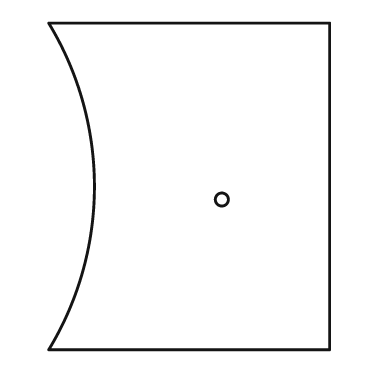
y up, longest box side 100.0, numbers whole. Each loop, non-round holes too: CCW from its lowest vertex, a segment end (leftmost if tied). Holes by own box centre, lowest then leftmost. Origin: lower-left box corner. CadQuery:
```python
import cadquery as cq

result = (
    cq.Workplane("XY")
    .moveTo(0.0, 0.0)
    .lineTo(86.0, 0.0)
    .lineTo(86.0, 100.0)
    .lineTo(0.0, 100.0)
    .threePointArc((14.0, 50.0), (0.0, 0.0))
    .close()
    .moveTo(53.0, 46.0)
    .circle(2.0)
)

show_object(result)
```